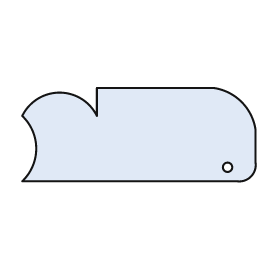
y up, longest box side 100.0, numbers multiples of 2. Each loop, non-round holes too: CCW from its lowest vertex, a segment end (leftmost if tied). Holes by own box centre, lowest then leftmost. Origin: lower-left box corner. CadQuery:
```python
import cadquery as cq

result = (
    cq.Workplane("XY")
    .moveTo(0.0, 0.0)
    .lineTo(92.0, 0.0)
    .threePointArc((98.0, 2.0), (100.0, 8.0))
    .lineTo(100.0, 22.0)
    .threePointArc((94.0, 34.0), (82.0, 40.0))
    .lineTo(32.0, 40.0)
    .lineTo(32.0, 28.0)
    .threePointArc((16.0, 38.0), (0.0, 28.0))
    .threePointArc((6.0, 14.0), (0.0, 0.0))
    .close()
    .moveTo(88.0, 6.0)
    .circle(2.0)
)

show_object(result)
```